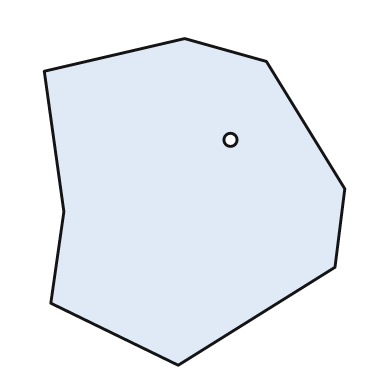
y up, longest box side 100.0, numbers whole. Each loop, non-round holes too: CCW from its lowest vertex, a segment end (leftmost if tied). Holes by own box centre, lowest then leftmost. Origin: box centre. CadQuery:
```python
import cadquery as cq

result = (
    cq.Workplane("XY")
    .moveTo(-5.0, -50.0)
    .lineTo(43.0, -20.0)
    .lineTo(46.0, 4.0)
    .lineTo(22.0, 43.0)
    .lineTo(-3.0, 50.0)
    .lineTo(-46.0, 40.0)
    .lineTo(-40.0, -3.0)
    .lineTo(-44.0, -31.0)
    .close()
    .moveTo(11.0, 19.0)
    .circle(2.0)
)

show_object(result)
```